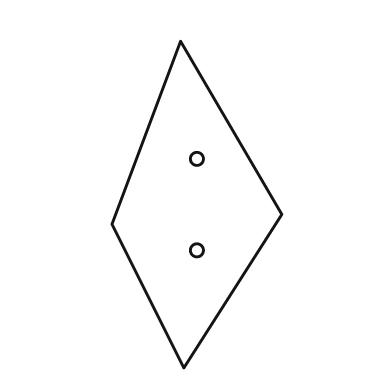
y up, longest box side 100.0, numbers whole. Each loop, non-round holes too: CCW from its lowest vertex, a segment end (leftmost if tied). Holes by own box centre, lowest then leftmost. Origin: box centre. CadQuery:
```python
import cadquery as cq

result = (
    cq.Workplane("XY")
    .moveTo(-4.0, -50.0)
    .lineTo(26.0, -3.0)
    .lineTo(-5.0, 50.0)
    .lineTo(-26.0, -6.0)
    .close()
    .moveTo(0.0, -14.0)
    .circle(2.0)
    .moveTo(0.0, 14.0)
    .circle(2.0)
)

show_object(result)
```